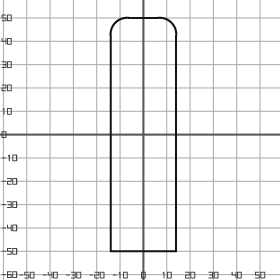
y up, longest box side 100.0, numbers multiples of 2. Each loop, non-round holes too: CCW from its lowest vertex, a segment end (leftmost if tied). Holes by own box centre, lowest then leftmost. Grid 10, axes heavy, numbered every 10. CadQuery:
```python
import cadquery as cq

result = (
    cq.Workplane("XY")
    .moveTo(-14.0, -50.0)
    .lineTo(14.0, -50.0)
    .lineTo(14.0, 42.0)
    .threePointArc((12.0, 48.0), (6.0, 50.0))
    .lineTo(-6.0, 50.0)
    .threePointArc((-12.0, 48.0), (-14.0, 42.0))
    .close()
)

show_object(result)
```